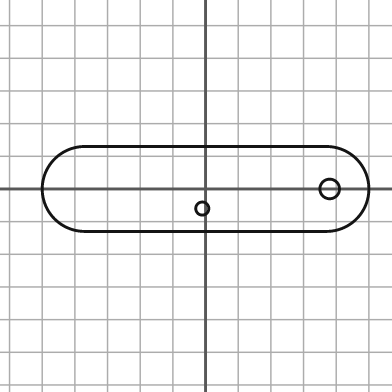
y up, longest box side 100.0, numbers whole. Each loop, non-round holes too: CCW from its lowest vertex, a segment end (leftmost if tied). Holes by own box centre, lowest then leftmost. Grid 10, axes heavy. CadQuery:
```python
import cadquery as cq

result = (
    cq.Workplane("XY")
    .moveTo(-37.0, -13.0)
    .lineTo(37.0, -13.0)
    .threePointArc((50.0, 0.0), (37.0, 13.0))
    .lineTo(-37.0, 13.0)
    .threePointArc((-50.0, 0.0), (-37.0, -13.0))
    .close()
    .moveTo(-1.0, -6.0)
    .circle(2.0)
    .moveTo(38.0, 0.0)
    .circle(3.0)
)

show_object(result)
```